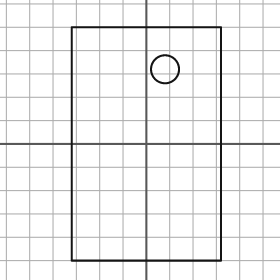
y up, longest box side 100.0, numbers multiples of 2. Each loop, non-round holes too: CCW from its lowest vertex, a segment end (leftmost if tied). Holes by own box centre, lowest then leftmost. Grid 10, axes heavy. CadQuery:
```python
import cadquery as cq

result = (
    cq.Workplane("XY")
    .moveTo(-32.0, -50.0)
    .lineTo(32.0, -50.0)
    .lineTo(32.0, 50.0)
    .lineTo(-32.0, 50.0)
    .close()
    .moveTo(8.0, 32.0)
    .circle(6.0)
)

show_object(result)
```